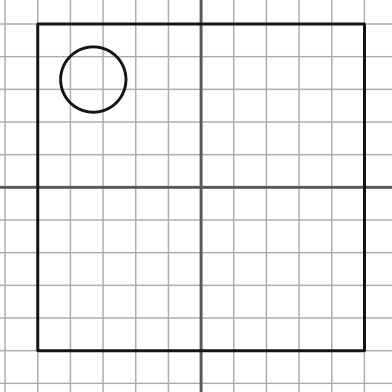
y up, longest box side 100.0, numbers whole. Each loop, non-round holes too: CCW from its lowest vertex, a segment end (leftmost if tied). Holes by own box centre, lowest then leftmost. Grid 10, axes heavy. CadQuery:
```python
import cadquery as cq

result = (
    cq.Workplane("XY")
    .moveTo(-50.0, -50.0)
    .lineTo(50.0, -50.0)
    .lineTo(50.0, 50.0)
    .lineTo(-50.0, 50.0)
    .close()
    .moveTo(-33.0, 33.0)
    .circle(10.0)
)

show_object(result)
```